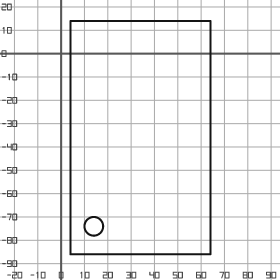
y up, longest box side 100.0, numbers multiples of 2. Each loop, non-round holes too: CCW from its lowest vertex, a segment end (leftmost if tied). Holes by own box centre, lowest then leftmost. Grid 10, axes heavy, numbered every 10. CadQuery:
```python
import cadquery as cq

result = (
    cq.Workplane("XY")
    .moveTo(4.0, -86.0)
    .lineTo(64.0, -86.0)
    .lineTo(64.0, 14.0)
    .lineTo(4.0, 14.0)
    .close()
    .moveTo(14.0, -74.0)
    .circle(4.0)
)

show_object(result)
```